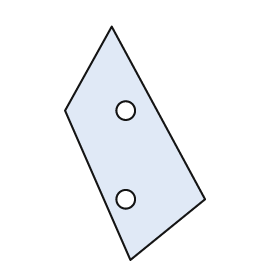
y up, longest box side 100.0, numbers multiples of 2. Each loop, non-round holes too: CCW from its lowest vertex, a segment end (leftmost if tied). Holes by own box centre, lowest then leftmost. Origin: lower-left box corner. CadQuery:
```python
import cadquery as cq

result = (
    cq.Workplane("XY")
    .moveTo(28.0, 0.0)
    .lineTo(60.0, 26.0)
    .lineTo(20.0, 100.0)
    .lineTo(0.0, 64.0)
    .close()
    .moveTo(26.0, 26.0)
    .circle(4.0)
    .moveTo(26.0, 64.0)
    .circle(4.0)
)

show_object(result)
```